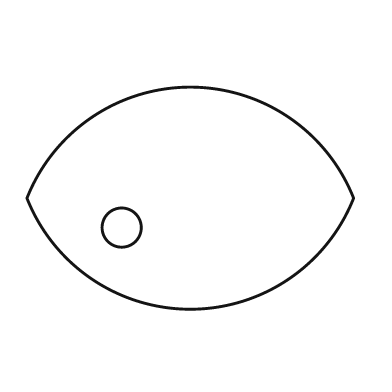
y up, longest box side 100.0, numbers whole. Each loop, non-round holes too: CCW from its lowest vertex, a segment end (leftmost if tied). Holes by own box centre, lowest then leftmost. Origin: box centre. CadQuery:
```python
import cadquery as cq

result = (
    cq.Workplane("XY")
    .moveTo(-50.0, 0.0)
    .threePointArc((0.0, -34.0), (50.0, 0.0))
    .threePointArc((0.0, 34.0), (-50.0, 0.0))
    .close()
    .moveTo(-21.0, -9.0)
    .circle(6.0)
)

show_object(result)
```